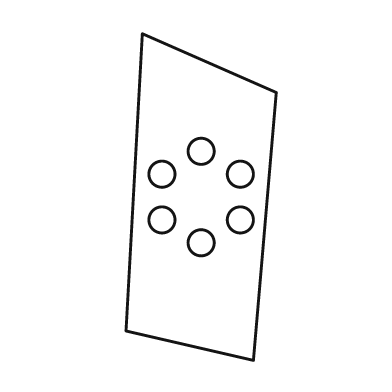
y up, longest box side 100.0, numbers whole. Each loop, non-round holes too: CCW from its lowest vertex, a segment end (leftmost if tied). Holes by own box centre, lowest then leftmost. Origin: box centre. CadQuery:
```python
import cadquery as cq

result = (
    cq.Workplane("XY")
    .moveTo(16.0, -50.0)
    .lineTo(23.0, 32.0)
    .lineTo(-18.0, 50.0)
    .lineTo(-23.0, -41.0)
    .close()
    .moveTo(0.0, -14.0)
    .circle(4.0)
    .moveTo(-12.0, -7.0)
    .circle(4.0)
    .moveTo(12.0, -7.0)
    .circle(4.0)
    .moveTo(-12.0, 7.0)
    .circle(4.0)
    .moveTo(12.0, 7.0)
    .circle(4.0)
    .moveTo(0.0, 14.0)
    .circle(4.0)
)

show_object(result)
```